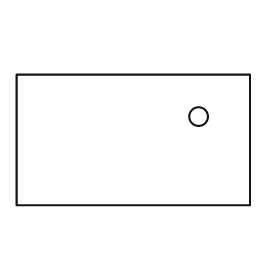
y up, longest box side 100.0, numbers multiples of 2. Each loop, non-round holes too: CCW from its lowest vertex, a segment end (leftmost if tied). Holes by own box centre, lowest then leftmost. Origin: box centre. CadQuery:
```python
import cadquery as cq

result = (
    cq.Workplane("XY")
    .moveTo(-50.0, -28.0)
    .lineTo(50.0, -28.0)
    .lineTo(50.0, 28.0)
    .lineTo(-50.0, 28.0)
    .close()
    .moveTo(28.0, 10.0)
    .circle(4.0)
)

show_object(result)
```